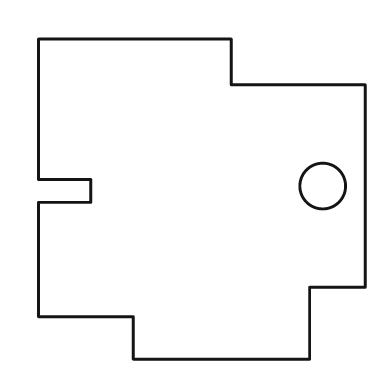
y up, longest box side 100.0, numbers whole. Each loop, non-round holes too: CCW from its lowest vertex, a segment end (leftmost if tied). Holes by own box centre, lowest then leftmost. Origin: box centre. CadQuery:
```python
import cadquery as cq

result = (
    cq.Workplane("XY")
    .moveTo(-21.0, -49.0)
    .lineTo(33.0, -49.0)
    .lineTo(33.0, -27.0)
    .lineTo(50.0, -27.0)
    .lineTo(50.0, 35.0)
    .lineTo(9.0, 35.0)
    .lineTo(9.0, 49.0)
    .lineTo(-50.0, 49.0)
    .lineTo(-50.0, 6.0)
    .lineTo(-34.0, 6.0)
    .lineTo(-34.0, -1.0)
    .lineTo(-50.0, -1.0)
    .lineTo(-50.0, -36.0)
    .lineTo(-21.0, -36.0)
    .close()
    .moveTo(37.0, 4.0)
    .circle(7.0)
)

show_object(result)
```